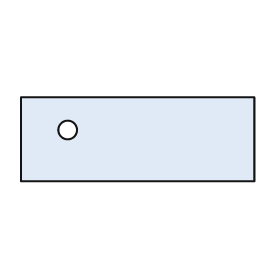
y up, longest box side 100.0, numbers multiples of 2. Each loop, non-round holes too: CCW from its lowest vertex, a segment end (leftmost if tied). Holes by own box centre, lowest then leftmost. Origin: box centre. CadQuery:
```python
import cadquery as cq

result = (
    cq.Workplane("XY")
    .moveTo(-50.0, -18.0)
    .lineTo(50.0, -18.0)
    .lineTo(50.0, 18.0)
    .lineTo(-50.0, 18.0)
    .close()
    .moveTo(-30.0, 4.0)
    .circle(4.0)
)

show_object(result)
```